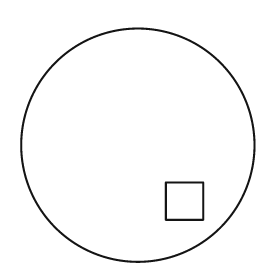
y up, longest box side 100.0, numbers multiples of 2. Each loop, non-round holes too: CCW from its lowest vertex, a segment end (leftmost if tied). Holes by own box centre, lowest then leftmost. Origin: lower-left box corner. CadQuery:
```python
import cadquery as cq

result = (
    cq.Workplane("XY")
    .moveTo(50.0, 50.0)
    .circle(50.0)
    .moveTo(62.0, 18.0)
    .lineTo(78.0, 18.0)
    .lineTo(78.0, 34.0)
    .lineTo(62.0, 34.0)
    .close()
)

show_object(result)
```